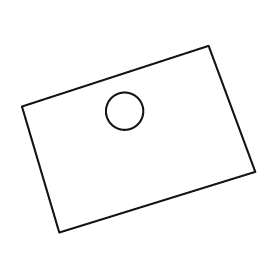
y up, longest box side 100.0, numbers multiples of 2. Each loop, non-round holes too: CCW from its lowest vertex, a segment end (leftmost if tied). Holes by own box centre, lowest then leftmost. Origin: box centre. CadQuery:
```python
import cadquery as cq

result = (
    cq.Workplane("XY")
    .moveTo(-34.0, -40.0)
    .lineTo(50.0, -14.0)
    .lineTo(30.0, 40.0)
    .lineTo(-50.0, 14.0)
    .close()
    .moveTo(-6.0, 12.0)
    .circle(8.0)
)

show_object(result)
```